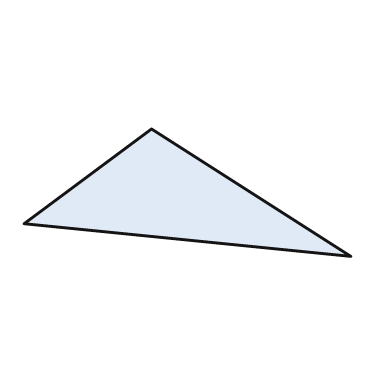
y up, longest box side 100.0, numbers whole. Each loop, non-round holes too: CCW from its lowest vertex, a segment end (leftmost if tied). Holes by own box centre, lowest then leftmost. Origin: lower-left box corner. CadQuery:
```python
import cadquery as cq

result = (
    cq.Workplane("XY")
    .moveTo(100.0, 0.0)
    .lineTo(39.0, 39.0)
    .lineTo(0.0, 10.0)
    .close()
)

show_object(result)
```